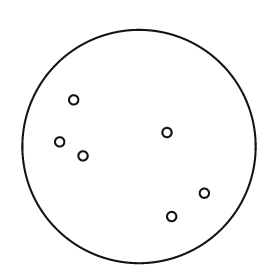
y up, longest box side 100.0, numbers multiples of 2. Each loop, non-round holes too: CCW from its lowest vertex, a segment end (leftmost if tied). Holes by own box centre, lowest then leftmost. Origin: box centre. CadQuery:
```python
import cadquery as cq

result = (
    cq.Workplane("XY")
    .moveTo(0.0, 0.0)
    .circle(50.0)
    .moveTo(14.0, -30.0)
    .circle(2.0)
    .moveTo(28.0, -20.0)
    .circle(2.0)
    .moveTo(-24.0, -4.0)
    .circle(2.0)
    .moveTo(-34.0, 2.0)
    .circle(2.0)
    .moveTo(12.0, 6.0)
    .circle(2.0)
    .moveTo(-28.0, 20.0)
    .circle(2.0)
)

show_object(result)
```